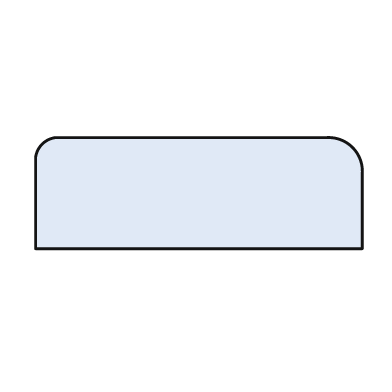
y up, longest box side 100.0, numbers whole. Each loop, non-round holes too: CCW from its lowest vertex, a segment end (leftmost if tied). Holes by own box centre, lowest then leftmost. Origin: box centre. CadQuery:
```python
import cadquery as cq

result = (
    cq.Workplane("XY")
    .moveTo(-50.0, -17.0)
    .lineTo(50.0, -17.0)
    .lineTo(50.0, 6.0)
    .threePointArc((47.0, 14.0), (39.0, 17.0))
    .lineTo(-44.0, 17.0)
    .threePointArc((-48.0, 15.0), (-50.0, 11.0))
    .close()
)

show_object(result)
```